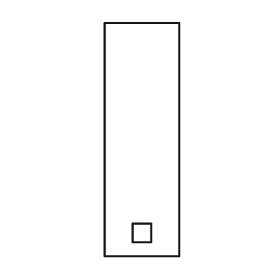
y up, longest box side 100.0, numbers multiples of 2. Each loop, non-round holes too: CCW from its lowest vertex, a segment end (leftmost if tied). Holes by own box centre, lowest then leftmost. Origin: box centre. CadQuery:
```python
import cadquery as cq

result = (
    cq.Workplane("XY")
    .moveTo(-16.0, -50.0)
    .lineTo(16.0, -50.0)
    .lineTo(16.0, 50.0)
    .lineTo(-16.0, 50.0)
    .close()
    .moveTo(-4.0, -44.0)
    .lineTo(4.0, -44.0)
    .lineTo(4.0, -36.0)
    .lineTo(-4.0, -36.0)
    .close()
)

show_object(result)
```